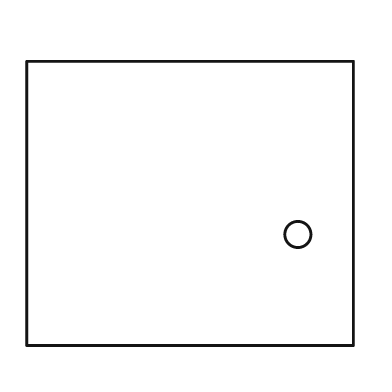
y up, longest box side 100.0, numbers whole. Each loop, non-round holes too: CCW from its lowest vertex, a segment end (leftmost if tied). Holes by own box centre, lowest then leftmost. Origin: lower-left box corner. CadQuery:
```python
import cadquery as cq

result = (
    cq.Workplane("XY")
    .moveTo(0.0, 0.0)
    .lineTo(100.0, 0.0)
    .lineTo(100.0, 87.0)
    .lineTo(0.0, 87.0)
    .close()
    .moveTo(83.0, 34.0)
    .circle(4.0)
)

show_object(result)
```